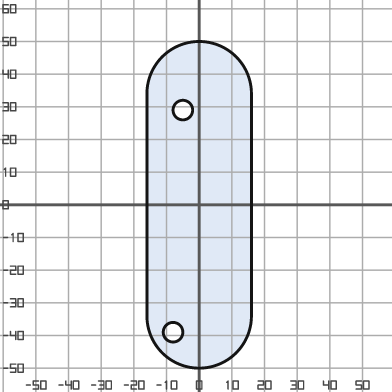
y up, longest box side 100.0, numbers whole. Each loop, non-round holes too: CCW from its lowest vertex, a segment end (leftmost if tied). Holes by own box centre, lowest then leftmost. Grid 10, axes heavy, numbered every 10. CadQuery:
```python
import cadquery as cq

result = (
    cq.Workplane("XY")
    .moveTo(-16.0, -34.0)
    .threePointArc((0.0, -50.0), (16.0, -34.0))
    .lineTo(16.0, 34.0)
    .threePointArc((0.0, 50.0), (-16.0, 34.0))
    .close()
    .moveTo(-8.0, -39.0)
    .circle(3.0)
    .moveTo(-5.0, 29.0)
    .circle(3.0)
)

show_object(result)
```